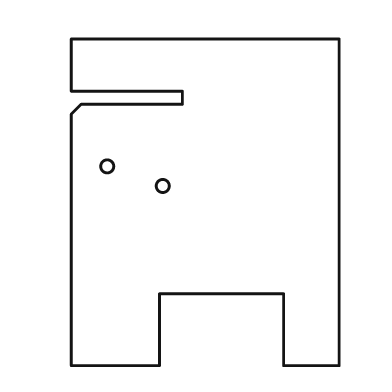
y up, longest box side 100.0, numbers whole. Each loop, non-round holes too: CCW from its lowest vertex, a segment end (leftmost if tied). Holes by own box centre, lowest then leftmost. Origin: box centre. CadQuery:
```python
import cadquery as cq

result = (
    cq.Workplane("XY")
    .moveTo(-41.0, -50.0)
    .lineTo(-14.0, -50.0)
    .lineTo(-14.0, -28.0)
    .lineTo(24.0, -28.0)
    .lineTo(24.0, -50.0)
    .lineTo(41.0, -50.0)
    .lineTo(41.0, 50.0)
    .lineTo(-41.0, 50.0)
    .lineTo(-41.0, 34.0)
    .lineTo(-7.0, 34.0)
    .lineTo(-7.0, 30.0)
    .lineTo(-38.0, 30.0)
    .lineTo(-41.0, 27.0)
    .close()
    .moveTo(-13.0, 5.0)
    .circle(2.0)
    .moveTo(-30.0, 11.0)
    .circle(2.0)
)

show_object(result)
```